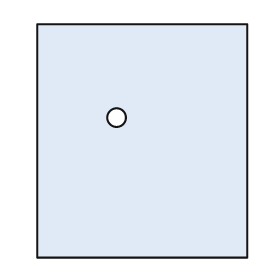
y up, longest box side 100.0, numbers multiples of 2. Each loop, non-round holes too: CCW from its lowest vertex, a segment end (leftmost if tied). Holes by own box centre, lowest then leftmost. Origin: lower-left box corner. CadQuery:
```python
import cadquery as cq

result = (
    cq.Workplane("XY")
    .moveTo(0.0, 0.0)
    .lineTo(90.0, 0.0)
    .lineTo(90.0, 100.0)
    .lineTo(0.0, 100.0)
    .close()
    .moveTo(34.0, 60.0)
    .circle(4.0)
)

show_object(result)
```